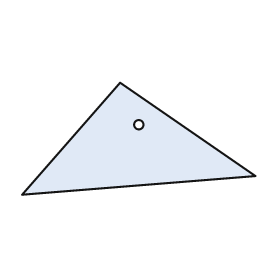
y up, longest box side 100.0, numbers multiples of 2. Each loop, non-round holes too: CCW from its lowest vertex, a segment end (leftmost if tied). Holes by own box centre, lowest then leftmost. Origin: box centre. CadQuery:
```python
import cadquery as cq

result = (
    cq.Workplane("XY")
    .moveTo(-50.0, -24.0)
    .lineTo(50.0, -16.0)
    .lineTo(-8.0, 24.0)
    .close()
    .moveTo(0.0, 6.0)
    .circle(2.0)
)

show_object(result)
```